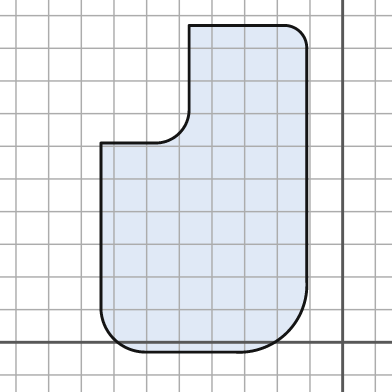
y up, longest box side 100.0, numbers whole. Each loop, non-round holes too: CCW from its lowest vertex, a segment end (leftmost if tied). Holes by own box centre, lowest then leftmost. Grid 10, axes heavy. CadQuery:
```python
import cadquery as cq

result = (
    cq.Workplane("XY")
    .moveTo(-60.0, -3.0)
    .lineTo(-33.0, -3.0)
    .threePointArc((-17.0, 3.0), (-11.0, 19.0))
    .lineTo(-11.0, 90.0)
    .threePointArc((-13.0, 95.0), (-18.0, 97.0))
    .lineTo(-47.0, 97.0)
    .lineTo(-47.0, 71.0)
    .threePointArc((-50.0, 64.0), (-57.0, 61.0))
    .lineTo(-74.0, 61.0)
    .lineTo(-74.0, 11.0)
    .threePointArc((-70.0, 1.0), (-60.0, -3.0))
    .close()
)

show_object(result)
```